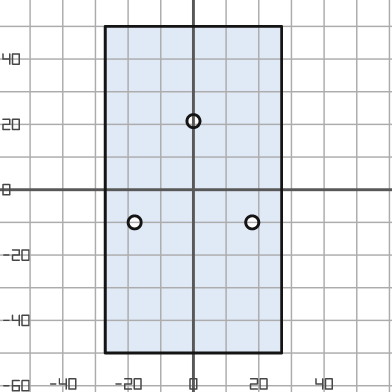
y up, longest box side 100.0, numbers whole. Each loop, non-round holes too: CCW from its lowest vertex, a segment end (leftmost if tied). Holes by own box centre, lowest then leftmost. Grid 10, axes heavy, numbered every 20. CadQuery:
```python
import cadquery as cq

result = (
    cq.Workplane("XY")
    .moveTo(-27.0, -50.0)
    .lineTo(27.0, -50.0)
    .lineTo(27.0, 50.0)
    .lineTo(-27.0, 50.0)
    .close()
    .moveTo(-18.0, -10.0)
    .circle(2.0)
    .moveTo(18.0, -10.0)
    .circle(2.0)
    .moveTo(0.0, 21.0)
    .circle(2.0)
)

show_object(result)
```